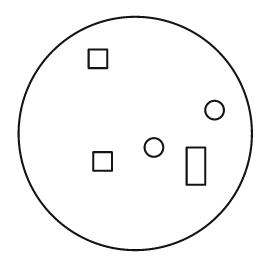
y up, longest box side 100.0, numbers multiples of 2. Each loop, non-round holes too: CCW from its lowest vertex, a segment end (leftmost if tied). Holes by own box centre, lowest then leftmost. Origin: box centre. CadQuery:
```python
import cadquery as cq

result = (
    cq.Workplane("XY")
    .moveTo(0.0, 0.0)
    .circle(50.0)
    .moveTo(22.0, -22.0)
    .lineTo(30.0, -22.0)
    .lineTo(30.0, -6.0)
    .lineTo(22.0, -6.0)
    .close()
    .moveTo(-18.0, -16.0)
    .lineTo(-10.0, -16.0)
    .lineTo(-10.0, -8.0)
    .lineTo(-18.0, -8.0)
    .close()
    .moveTo(8.0, -6.0)
    .circle(4.0)
    .moveTo(34.0, 10.0)
    .circle(4.0)
    .moveTo(-20.0, 28.0)
    .lineTo(-12.0, 28.0)
    .lineTo(-12.0, 36.0)
    .lineTo(-20.0, 36.0)
    .close()
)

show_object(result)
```